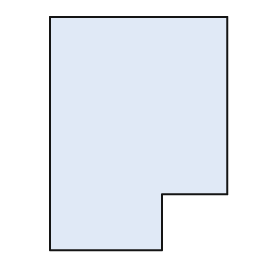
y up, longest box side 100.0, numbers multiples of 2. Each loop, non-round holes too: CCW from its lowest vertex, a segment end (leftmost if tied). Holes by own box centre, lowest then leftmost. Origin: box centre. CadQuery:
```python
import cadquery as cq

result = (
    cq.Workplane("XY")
    .moveTo(-38.0, -50.0)
    .lineTo(10.0, -50.0)
    .lineTo(10.0, -26.0)
    .lineTo(38.0, -26.0)
    .lineTo(38.0, 50.0)
    .lineTo(-38.0, 50.0)
    .close()
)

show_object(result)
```